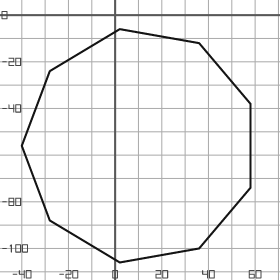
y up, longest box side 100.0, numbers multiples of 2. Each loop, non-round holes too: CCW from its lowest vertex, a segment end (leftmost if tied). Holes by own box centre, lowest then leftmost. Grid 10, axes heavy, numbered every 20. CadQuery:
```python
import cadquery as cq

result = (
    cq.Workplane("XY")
    .moveTo(2.0, -106.0)
    .lineTo(36.0, -100.0)
    .lineTo(58.0, -74.0)
    .lineTo(58.0, -38.0)
    .lineTo(36.0, -12.0)
    .lineTo(2.0, -6.0)
    .lineTo(-28.0, -24.0)
    .lineTo(-40.0, -56.0)
    .lineTo(-28.0, -88.0)
    .close()
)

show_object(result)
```